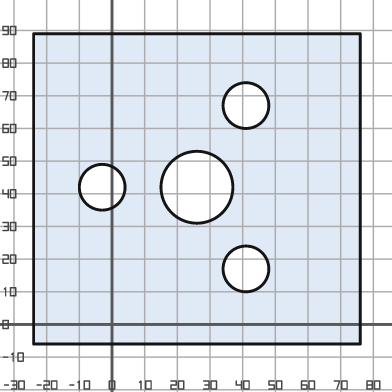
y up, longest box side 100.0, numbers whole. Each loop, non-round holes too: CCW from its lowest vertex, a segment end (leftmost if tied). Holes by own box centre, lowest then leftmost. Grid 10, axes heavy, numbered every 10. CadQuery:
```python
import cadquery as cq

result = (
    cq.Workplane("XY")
    .moveTo(-24.0, -6.0)
    .lineTo(76.0, -6.0)
    .lineTo(76.0, 89.0)
    .lineTo(-24.0, 89.0)
    .close()
    .moveTo(41.0, 17.0)
    .circle(7.0)
    .moveTo(-3.0, 42.0)
    .circle(7.0)
    .moveTo(26.0, 42.0)
    .circle(11.0)
    .moveTo(41.0, 67.0)
    .circle(7.0)
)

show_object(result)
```